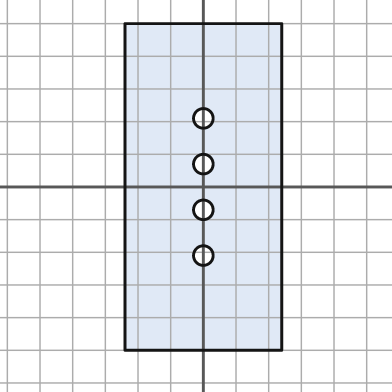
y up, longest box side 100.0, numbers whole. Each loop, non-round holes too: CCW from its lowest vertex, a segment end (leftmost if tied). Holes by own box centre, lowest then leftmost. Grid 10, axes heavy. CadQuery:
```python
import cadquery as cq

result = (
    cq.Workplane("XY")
    .moveTo(-24.0, -50.0)
    .lineTo(24.0, -50.0)
    .lineTo(24.0, 50.0)
    .lineTo(-24.0, 50.0)
    .close()
    .moveTo(0.0, -21.0)
    .circle(3.0)
    .moveTo(0.0, -7.0)
    .circle(3.0)
    .moveTo(0.0, 7.0)
    .circle(3.0)
    .moveTo(0.0, 21.0)
    .circle(3.0)
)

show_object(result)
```